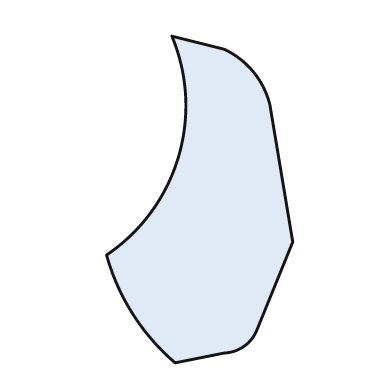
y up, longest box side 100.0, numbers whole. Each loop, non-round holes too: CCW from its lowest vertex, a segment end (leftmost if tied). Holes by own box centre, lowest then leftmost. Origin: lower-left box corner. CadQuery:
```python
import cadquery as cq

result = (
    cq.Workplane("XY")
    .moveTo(21.0, 0.0)
    .lineTo(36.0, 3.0)
    .threePointArc((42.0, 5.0), (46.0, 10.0))
    .lineTo(57.0, 37.0)
    .lineTo(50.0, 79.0)
    .threePointArc((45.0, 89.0), (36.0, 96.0))
    .lineTo(20.0, 100.0)
    .threePointArc((22.0, 63.0), (0.0, 33.0))
    .threePointArc((8.0, 15.0), (21.0, 0.0))
    .close()
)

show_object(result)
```